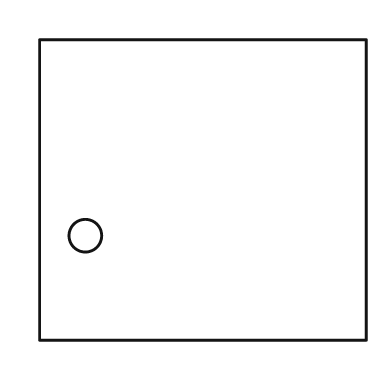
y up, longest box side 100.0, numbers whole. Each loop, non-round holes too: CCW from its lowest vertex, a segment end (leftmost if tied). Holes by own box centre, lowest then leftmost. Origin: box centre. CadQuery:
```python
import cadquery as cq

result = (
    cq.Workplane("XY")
    .moveTo(-50.0, -46.0)
    .lineTo(50.0, -46.0)
    .lineTo(50.0, 46.0)
    .lineTo(-50.0, 46.0)
    .close()
    .moveTo(-36.0, -14.0)
    .circle(5.0)
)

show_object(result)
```